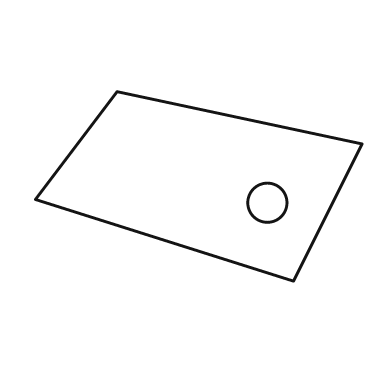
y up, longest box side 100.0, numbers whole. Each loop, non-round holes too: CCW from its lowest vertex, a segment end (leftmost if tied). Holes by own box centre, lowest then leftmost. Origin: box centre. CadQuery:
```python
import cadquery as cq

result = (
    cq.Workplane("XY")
    .moveTo(29.0, -29.0)
    .lineTo(50.0, 13.0)
    .lineTo(-25.0, 29.0)
    .lineTo(-50.0, -4.0)
    .close()
    .moveTo(21.0, -5.0)
    .circle(6.0)
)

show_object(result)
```